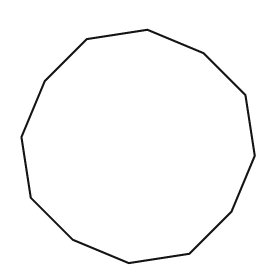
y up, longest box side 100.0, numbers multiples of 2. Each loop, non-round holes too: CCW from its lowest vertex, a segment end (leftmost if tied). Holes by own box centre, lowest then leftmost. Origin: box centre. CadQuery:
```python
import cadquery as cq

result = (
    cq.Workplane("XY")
    .moveTo(-4.0, -50.0)
    .lineTo(22.0, -46.0)
    .lineTo(40.0, -28.0)
    .lineTo(50.0, -4.0)
    .lineTo(46.0, 22.0)
    .lineTo(28.0, 40.0)
    .lineTo(4.0, 50.0)
    .lineTo(-22.0, 46.0)
    .lineTo(-40.0, 28.0)
    .lineTo(-50.0, 4.0)
    .lineTo(-46.0, -22.0)
    .lineTo(-28.0, -40.0)
    .close()
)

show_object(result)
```